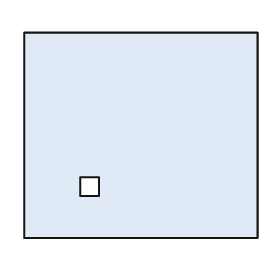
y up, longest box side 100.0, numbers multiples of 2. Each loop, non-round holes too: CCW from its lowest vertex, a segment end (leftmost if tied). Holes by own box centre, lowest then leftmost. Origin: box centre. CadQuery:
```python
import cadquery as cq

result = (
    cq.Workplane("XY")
    .moveTo(-50.0, -44.0)
    .lineTo(50.0, -44.0)
    .lineTo(50.0, 44.0)
    .lineTo(-50.0, 44.0)
    .close()
    .moveTo(-26.0, -26.0)
    .lineTo(-18.0, -26.0)
    .lineTo(-18.0, -18.0)
    .lineTo(-26.0, -18.0)
    .close()
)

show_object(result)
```